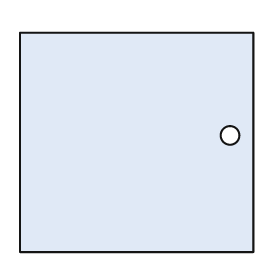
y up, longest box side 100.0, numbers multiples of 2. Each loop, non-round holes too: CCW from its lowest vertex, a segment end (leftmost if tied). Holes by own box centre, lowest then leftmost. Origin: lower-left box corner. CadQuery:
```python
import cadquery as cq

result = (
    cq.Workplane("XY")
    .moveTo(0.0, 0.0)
    .lineTo(100.0, 0.0)
    .lineTo(100.0, 94.0)
    .lineTo(0.0, 94.0)
    .close()
    .moveTo(90.0, 50.0)
    .circle(4.0)
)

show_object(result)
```